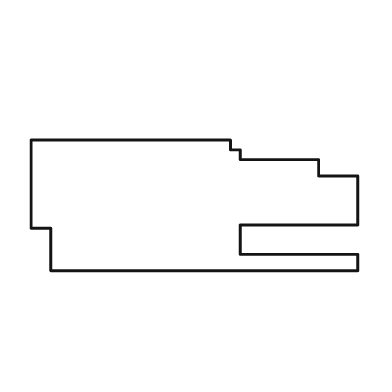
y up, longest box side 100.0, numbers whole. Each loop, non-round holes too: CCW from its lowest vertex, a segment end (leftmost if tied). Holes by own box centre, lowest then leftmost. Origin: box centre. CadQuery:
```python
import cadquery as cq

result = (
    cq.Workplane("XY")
    .moveTo(-44.0, -20.0)
    .lineTo(50.0, -20.0)
    .lineTo(50.0, -15.0)
    .lineTo(14.0, -15.0)
    .lineTo(14.0, -6.0)
    .lineTo(50.0, -6.0)
    .lineTo(50.0, 9.0)
    .lineTo(38.0, 9.0)
    .lineTo(38.0, 14.0)
    .lineTo(14.0, 14.0)
    .lineTo(14.0, 17.0)
    .lineTo(11.0, 17.0)
    .lineTo(11.0, 20.0)
    .lineTo(-50.0, 20.0)
    .lineTo(-50.0, -7.0)
    .lineTo(-44.0, -7.0)
    .close()
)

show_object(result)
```